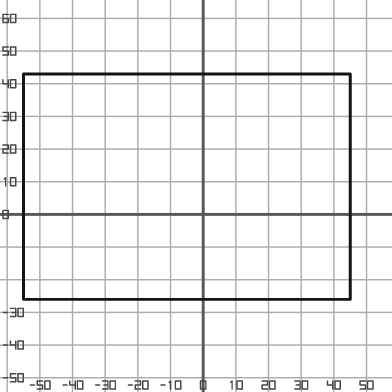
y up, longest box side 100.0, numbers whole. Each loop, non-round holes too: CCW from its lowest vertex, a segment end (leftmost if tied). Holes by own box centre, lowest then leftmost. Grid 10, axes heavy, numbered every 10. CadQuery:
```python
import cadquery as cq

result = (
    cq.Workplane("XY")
    .moveTo(-55.0, -26.0)
    .lineTo(45.0, -26.0)
    .lineTo(45.0, 43.0)
    .lineTo(-55.0, 43.0)
    .close()
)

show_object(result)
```